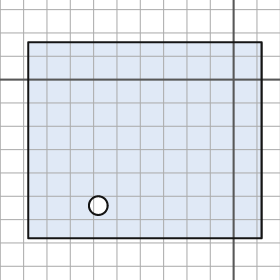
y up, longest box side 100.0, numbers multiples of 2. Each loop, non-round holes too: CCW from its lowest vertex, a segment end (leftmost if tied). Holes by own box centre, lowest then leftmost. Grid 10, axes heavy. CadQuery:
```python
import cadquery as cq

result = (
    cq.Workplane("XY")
    .moveTo(-88.0, -68.0)
    .lineTo(12.0, -68.0)
    .lineTo(12.0, 16.0)
    .lineTo(-88.0, 16.0)
    .close()
    .moveTo(-58.0, -54.0)
    .circle(4.0)
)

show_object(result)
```